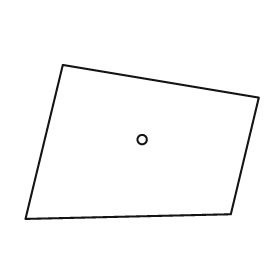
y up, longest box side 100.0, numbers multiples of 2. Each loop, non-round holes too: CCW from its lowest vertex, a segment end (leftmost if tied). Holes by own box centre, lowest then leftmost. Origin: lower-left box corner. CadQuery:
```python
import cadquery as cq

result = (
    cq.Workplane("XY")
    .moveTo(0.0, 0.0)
    .lineTo(88.0, 2.0)
    .lineTo(100.0, 52.0)
    .lineTo(16.0, 66.0)
    .close()
    .moveTo(50.0, 34.0)
    .circle(2.0)
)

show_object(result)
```